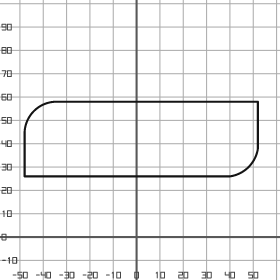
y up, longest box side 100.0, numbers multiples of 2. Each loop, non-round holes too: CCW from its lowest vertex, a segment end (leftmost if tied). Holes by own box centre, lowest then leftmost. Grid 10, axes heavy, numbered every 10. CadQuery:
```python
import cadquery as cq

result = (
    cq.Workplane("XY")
    .moveTo(-48.0, 26.0)
    .lineTo(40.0, 26.0)
    .threePointArc((48.0, 30.0), (52.0, 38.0))
    .lineTo(52.0, 58.0)
    .lineTo(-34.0, 58.0)
    .threePointArc((-44.0, 54.0), (-48.0, 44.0))
    .close()
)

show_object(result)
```